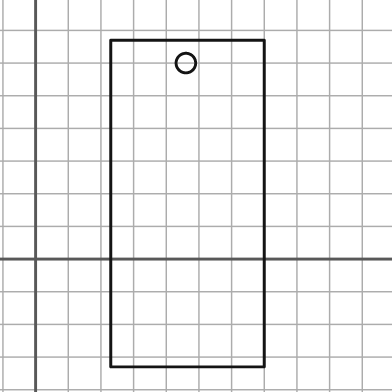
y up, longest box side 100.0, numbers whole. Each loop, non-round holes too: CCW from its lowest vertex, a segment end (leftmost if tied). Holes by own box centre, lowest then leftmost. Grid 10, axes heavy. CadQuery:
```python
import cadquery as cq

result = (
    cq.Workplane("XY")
    .moveTo(23.0, -33.0)
    .lineTo(70.0, -33.0)
    .lineTo(70.0, 67.0)
    .lineTo(23.0, 67.0)
    .close()
    .moveTo(46.0, 60.0)
    .circle(3.0)
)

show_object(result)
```